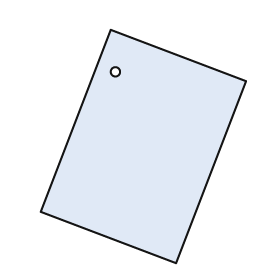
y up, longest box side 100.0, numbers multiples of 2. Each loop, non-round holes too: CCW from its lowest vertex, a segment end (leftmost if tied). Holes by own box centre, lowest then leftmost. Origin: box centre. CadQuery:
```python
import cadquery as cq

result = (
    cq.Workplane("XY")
    .moveTo(14.0, -50.0)
    .lineTo(44.0, 28.0)
    .lineTo(-14.0, 50.0)
    .lineTo(-44.0, -28.0)
    .close()
    .moveTo(-12.0, 32.0)
    .circle(2.0)
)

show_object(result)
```